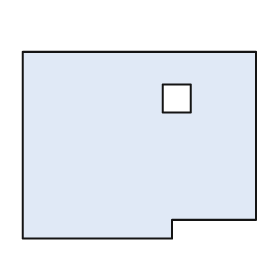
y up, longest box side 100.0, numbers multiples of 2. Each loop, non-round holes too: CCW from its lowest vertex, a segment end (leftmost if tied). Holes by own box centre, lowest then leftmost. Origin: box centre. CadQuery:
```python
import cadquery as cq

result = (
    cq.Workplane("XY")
    .moveTo(-50.0, -40.0)
    .lineTo(14.0, -40.0)
    .lineTo(14.0, -32.0)
    .lineTo(50.0, -32.0)
    .lineTo(50.0, 40.0)
    .lineTo(-50.0, 40.0)
    .close()
    .moveTo(10.0, 14.0)
    .lineTo(22.0, 14.0)
    .lineTo(22.0, 26.0)
    .lineTo(10.0, 26.0)
    .close()
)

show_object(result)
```